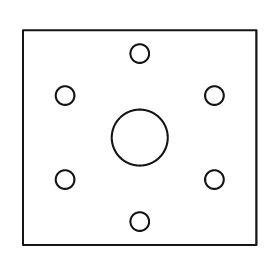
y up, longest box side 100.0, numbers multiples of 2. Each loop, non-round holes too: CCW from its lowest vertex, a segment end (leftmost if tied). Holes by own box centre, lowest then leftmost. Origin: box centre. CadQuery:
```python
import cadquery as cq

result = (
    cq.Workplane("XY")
    .moveTo(-50.0, -46.0)
    .lineTo(50.0, -46.0)
    .lineTo(50.0, 46.0)
    .lineTo(-50.0, 46.0)
    .close()
    .moveTo(0.0, -36.0)
    .circle(4.0)
    .moveTo(-32.0, -18.0)
    .circle(4.0)
    .moveTo(32.0, -18.0)
    .circle(4.0)
    .moveTo(0.0, 0.0)
    .circle(12.0)
    .moveTo(-32.0, 18.0)
    .circle(4.0)
    .moveTo(32.0, 18.0)
    .circle(4.0)
    .moveTo(0.0, 36.0)
    .circle(4.0)
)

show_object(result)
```